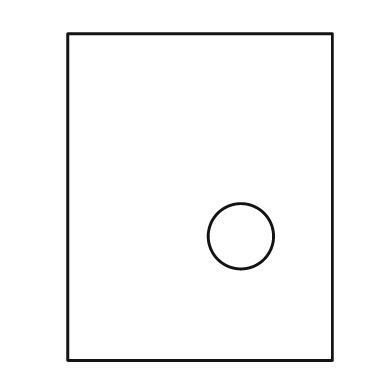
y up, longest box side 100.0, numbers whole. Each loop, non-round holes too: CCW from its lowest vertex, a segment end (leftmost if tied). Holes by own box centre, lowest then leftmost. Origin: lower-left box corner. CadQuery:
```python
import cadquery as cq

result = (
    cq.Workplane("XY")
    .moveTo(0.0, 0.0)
    .lineTo(81.0, 0.0)
    .lineTo(81.0, 100.0)
    .lineTo(0.0, 100.0)
    .close()
    .moveTo(53.0, 38.0)
    .circle(10.0)
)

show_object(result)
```